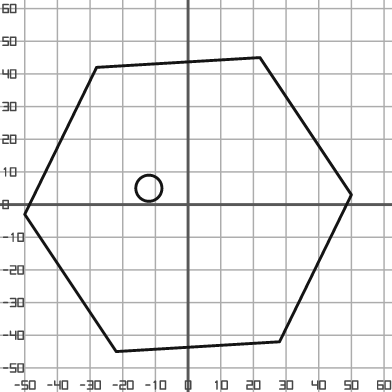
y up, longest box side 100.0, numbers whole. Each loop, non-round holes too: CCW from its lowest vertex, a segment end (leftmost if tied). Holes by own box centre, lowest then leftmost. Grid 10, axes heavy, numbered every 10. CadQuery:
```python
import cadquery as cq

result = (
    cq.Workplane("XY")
    .moveTo(-22.0, -45.0)
    .lineTo(28.0, -42.0)
    .lineTo(50.0, 3.0)
    .lineTo(22.0, 45.0)
    .lineTo(-28.0, 42.0)
    .lineTo(-50.0, -3.0)
    .close()
    .moveTo(-12.0, 5.0)
    .circle(4.0)
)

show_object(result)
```